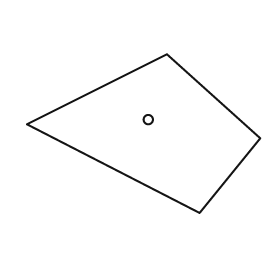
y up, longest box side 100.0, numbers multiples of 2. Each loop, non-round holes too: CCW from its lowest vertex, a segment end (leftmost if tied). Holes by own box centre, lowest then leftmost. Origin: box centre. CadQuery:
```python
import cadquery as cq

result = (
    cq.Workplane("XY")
    .moveTo(24.0, -34.0)
    .lineTo(50.0, -2.0)
    .lineTo(10.0, 34.0)
    .lineTo(-50.0, 4.0)
    .close()
    .moveTo(2.0, 6.0)
    .circle(2.0)
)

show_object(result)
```